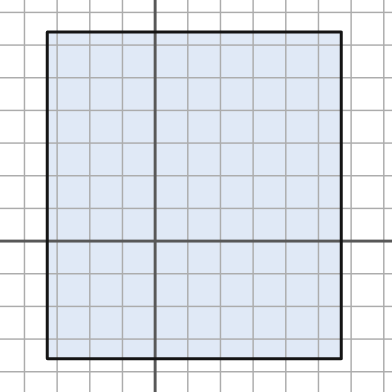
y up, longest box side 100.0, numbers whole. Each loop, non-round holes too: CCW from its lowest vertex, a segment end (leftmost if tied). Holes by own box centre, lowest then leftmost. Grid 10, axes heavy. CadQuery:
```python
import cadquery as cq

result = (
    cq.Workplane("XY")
    .moveTo(-33.0, -36.0)
    .lineTo(57.0, -36.0)
    .lineTo(57.0, 64.0)
    .lineTo(-33.0, 64.0)
    .close()
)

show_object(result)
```